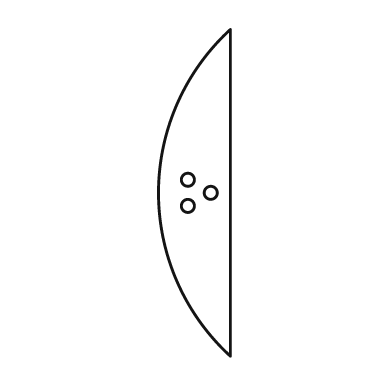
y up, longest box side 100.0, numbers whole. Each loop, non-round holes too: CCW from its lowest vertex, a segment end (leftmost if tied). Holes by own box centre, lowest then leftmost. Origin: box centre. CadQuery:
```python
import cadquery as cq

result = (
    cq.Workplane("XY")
    .moveTo(11.0, -50.0)
    .lineTo(11.0, 50.0)
    .threePointArc((-11.0, 0.0), (11.0, -50.0))
    .close()
    .moveTo(-2.0, -4.0)
    .circle(2.0)
    .moveTo(5.0, 0.0)
    .circle(2.0)
    .moveTo(-2.0, 4.0)
    .circle(2.0)
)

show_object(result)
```